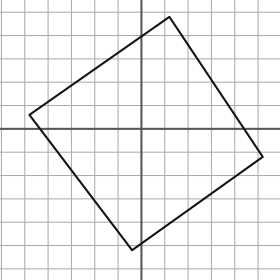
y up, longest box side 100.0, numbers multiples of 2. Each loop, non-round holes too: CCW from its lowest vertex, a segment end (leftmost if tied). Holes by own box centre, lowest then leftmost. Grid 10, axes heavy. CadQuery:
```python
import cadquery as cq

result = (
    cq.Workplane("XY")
    .moveTo(-4.0, -52.0)
    .lineTo(52.0, -12.0)
    .lineTo(12.0, 48.0)
    .lineTo(-48.0, 6.0)
    .close()
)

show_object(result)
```